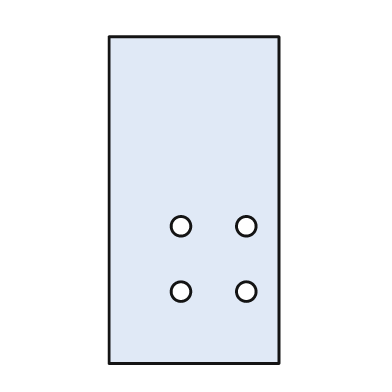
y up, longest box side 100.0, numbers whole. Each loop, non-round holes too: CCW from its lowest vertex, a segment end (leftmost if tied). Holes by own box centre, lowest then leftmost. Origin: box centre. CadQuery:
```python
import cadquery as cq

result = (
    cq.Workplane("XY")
    .moveTo(-26.0, -50.0)
    .lineTo(26.0, -50.0)
    .lineTo(26.0, 50.0)
    .lineTo(-26.0, 50.0)
    .close()
    .moveTo(-4.0, -28.0)
    .circle(3.0)
    .moveTo(16.0, -28.0)
    .circle(3.0)
    .moveTo(-4.0, -8.0)
    .circle(3.0)
    .moveTo(16.0, -8.0)
    .circle(3.0)
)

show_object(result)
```